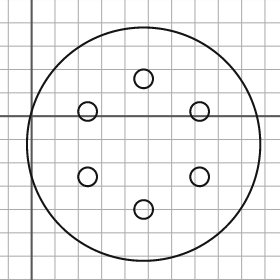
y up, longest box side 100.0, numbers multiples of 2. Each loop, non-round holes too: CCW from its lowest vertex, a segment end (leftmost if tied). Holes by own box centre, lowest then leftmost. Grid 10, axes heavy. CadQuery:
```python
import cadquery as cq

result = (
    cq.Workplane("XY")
    .moveTo(48.0, -12.0)
    .circle(50.0)
    .moveTo(48.0, -40.0)
    .circle(4.0)
    .moveTo(24.0, -26.0)
    .circle(4.0)
    .moveTo(72.0, -26.0)
    .circle(4.0)
    .moveTo(24.0, 2.0)
    .circle(4.0)
    .moveTo(72.0, 2.0)
    .circle(4.0)
    .moveTo(48.0, 16.0)
    .circle(4.0)
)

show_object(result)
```